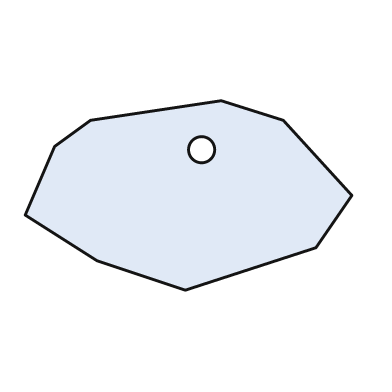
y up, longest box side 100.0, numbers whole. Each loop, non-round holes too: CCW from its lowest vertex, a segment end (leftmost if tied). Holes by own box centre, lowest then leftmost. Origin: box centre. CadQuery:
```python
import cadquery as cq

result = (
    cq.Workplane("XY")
    .moveTo(-1.0, -29.0)
    .lineTo(39.0, -16.0)
    .lineTo(50.0, 0.0)
    .lineTo(29.0, 23.0)
    .lineTo(10.0, 29.0)
    .lineTo(-30.0, 23.0)
    .lineTo(-41.0, 15.0)
    .lineTo(-50.0, -6.0)
    .lineTo(-28.0, -20.0)
    .close()
    .moveTo(4.0, 14.0)
    .circle(4.0)
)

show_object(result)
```